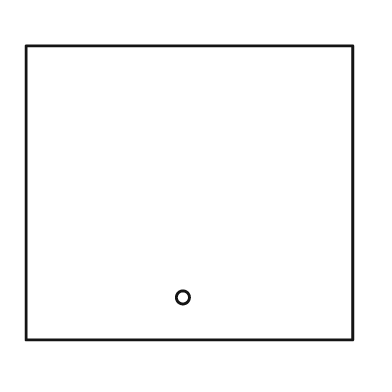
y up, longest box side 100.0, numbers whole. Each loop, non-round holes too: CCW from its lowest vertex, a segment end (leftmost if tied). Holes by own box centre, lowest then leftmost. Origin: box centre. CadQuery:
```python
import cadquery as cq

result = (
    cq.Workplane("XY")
    .moveTo(-50.0, -45.0)
    .lineTo(50.0, -45.0)
    .lineTo(50.0, 45.0)
    .lineTo(-50.0, 45.0)
    .close()
    .moveTo(-2.0, -32.0)
    .circle(2.0)
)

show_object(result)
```